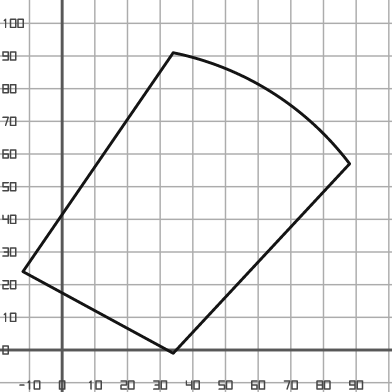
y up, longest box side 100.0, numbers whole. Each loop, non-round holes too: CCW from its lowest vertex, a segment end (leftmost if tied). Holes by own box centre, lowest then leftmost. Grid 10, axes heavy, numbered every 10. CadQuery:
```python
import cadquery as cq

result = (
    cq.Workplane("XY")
    .moveTo(34.0, -1.0)
    .lineTo(88.0, 57.0)
    .threePointArc((64.0, 79.0), (34.0, 91.0))
    .lineTo(-12.0, 24.0)
    .close()
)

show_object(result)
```